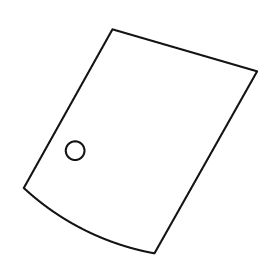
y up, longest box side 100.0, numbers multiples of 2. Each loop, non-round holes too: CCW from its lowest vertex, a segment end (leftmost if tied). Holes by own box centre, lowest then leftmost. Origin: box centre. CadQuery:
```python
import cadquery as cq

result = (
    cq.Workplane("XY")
    .moveTo(6.0, -48.0)
    .lineTo(50.0, 30.0)
    .lineTo(-12.0, 48.0)
    .lineTo(-50.0, -20.0)
    .threePointArc((-24.0, -38.0), (6.0, -48.0))
    .close()
    .moveTo(-28.0, -4.0)
    .circle(4.0)
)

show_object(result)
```